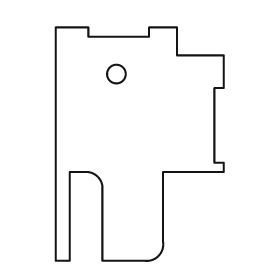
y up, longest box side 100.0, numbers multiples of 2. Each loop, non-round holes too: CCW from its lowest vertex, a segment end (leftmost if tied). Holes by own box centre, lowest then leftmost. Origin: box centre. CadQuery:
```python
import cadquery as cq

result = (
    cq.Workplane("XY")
    .moveTo(-36.0, -50.0)
    .lineTo(-30.0, -50.0)
    .lineTo(-30.0, -12.0)
    .lineTo(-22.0, -12.0)
    .threePointArc((-18.0, -14.0), (-16.0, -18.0))
    .lineTo(-16.0, -50.0)
    .lineTo(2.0, -50.0)
    .threePointArc((8.0, -48.0), (10.0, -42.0))
    .lineTo(10.0, -12.0)
    .lineTo(36.0, -12.0)
    .lineTo(36.0, -8.0)
    .lineTo(32.0, -8.0)
    .lineTo(32.0, 24.0)
    .lineTo(36.0, 24.0)
    .lineTo(36.0, 38.0)
    .lineTo(16.0, 38.0)
    .lineTo(16.0, 50.0)
    .lineTo(4.0, 50.0)
    .lineTo(4.0, 46.0)
    .lineTo(-22.0, 46.0)
    .lineTo(-22.0, 50.0)
    .lineTo(-36.0, 50.0)
    .close()
    .moveTo(-10.0, 30.0)
    .circle(4.0)
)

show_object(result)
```